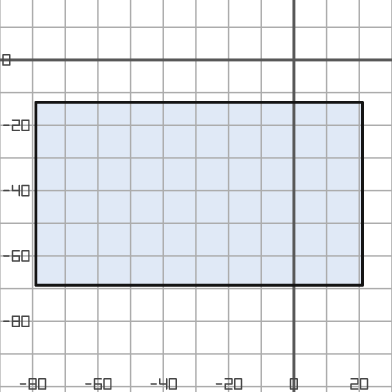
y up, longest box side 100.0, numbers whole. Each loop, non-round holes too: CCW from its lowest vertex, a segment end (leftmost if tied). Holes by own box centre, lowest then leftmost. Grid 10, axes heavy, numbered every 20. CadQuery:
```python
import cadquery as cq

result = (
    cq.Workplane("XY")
    .moveTo(-79.0, -69.0)
    .lineTo(21.0, -69.0)
    .lineTo(21.0, -13.0)
    .lineTo(-79.0, -13.0)
    .close()
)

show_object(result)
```